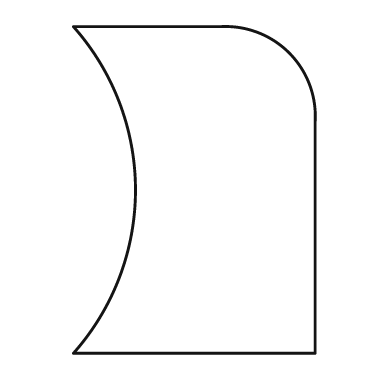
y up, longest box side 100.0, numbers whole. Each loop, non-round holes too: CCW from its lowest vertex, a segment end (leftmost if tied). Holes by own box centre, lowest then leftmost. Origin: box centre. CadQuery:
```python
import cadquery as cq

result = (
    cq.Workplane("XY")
    .moveTo(-37.0, -50.0)
    .lineTo(37.0, -50.0)
    .lineTo(37.0, 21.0)
    .threePointArc((29.0, 42.0), (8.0, 50.0))
    .lineTo(-37.0, 50.0)
    .threePointArc((-18.0, 0.0), (-37.0, -50.0))
    .close()
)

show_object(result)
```